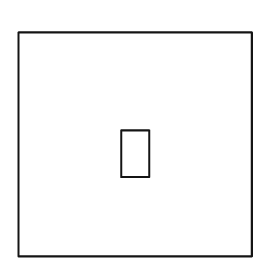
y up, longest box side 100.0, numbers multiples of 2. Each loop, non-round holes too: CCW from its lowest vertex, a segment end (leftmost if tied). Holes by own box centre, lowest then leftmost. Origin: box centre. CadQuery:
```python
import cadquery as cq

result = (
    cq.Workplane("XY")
    .moveTo(-50.0, -48.0)
    .lineTo(50.0, -48.0)
    .lineTo(50.0, 48.0)
    .lineTo(-50.0, 48.0)
    .close()
    .moveTo(-6.0, -14.0)
    .lineTo(6.0, -14.0)
    .lineTo(6.0, 6.0)
    .lineTo(-6.0, 6.0)
    .close()
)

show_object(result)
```